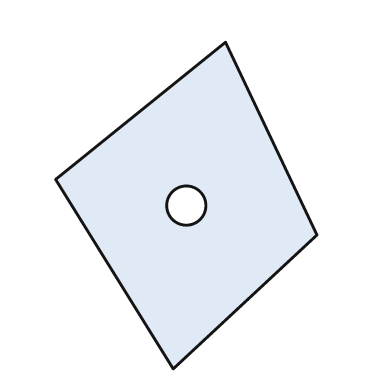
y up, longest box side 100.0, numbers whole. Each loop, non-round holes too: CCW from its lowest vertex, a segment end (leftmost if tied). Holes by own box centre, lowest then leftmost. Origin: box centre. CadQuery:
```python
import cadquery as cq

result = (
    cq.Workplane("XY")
    .moveTo(-4.0, -50.0)
    .lineTo(40.0, -9.0)
    .lineTo(12.0, 50.0)
    .lineTo(-40.0, 8.0)
    .close()
    .moveTo(0.0, 0.0)
    .circle(6.0)
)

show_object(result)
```